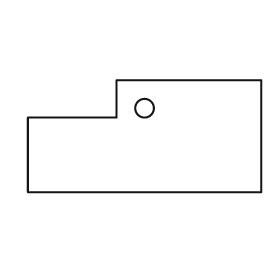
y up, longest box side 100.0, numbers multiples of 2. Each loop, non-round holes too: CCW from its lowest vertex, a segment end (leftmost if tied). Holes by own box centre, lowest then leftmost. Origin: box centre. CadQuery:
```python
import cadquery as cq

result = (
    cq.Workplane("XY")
    .moveTo(-50.0, -24.0)
    .lineTo(50.0, -24.0)
    .lineTo(50.0, 24.0)
    .lineTo(-12.0, 24.0)
    .lineTo(-12.0, 8.0)
    .lineTo(-50.0, 8.0)
    .close()
    .moveTo(0.0, 12.0)
    .circle(4.0)
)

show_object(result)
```